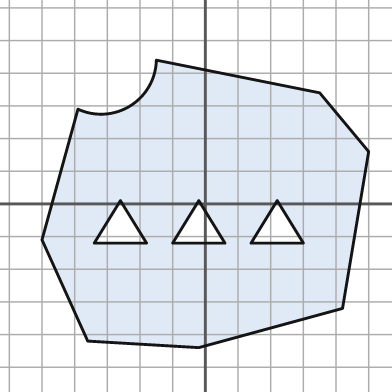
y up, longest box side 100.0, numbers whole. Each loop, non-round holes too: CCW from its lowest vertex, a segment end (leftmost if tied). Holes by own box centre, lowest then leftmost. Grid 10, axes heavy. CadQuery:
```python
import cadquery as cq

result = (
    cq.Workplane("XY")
    .moveTo(-2.0, -44.0)
    .lineTo(42.0, -32.0)
    .lineTo(50.0, 16.0)
    .lineTo(35.0, 34.0)
    .lineTo(-15.0, 44.0)
    .threePointArc((-23.0, 30.0), (-39.0, 29.0))
    .lineTo(-50.0, -11.0)
    .lineTo(-36.0, -42.0)
    .close()
    .moveTo(-34.0, -12.0)
    .lineTo(-18.0, -12.0)
    .lineTo(-26.0, 1.0)
    .close()
    .moveTo(-10.0, -12.0)
    .lineTo(6.0, -12.0)
    .lineTo(-2.0, 1.0)
    .close()
    .moveTo(14.0, -12.0)
    .lineTo(30.0, -12.0)
    .lineTo(22.0, 1.0)
    .close()
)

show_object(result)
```